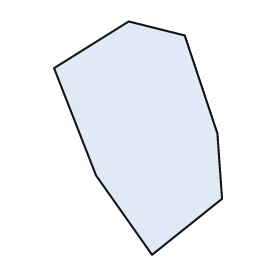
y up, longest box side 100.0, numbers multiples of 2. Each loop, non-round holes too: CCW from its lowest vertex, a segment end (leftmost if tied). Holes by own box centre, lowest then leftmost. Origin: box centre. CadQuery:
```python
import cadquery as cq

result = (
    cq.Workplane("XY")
    .moveTo(6.0, -50.0)
    .lineTo(36.0, -26.0)
    .lineTo(34.0, 2.0)
    .lineTo(20.0, 44.0)
    .lineTo(-4.0, 50.0)
    .lineTo(-36.0, 30.0)
    .lineTo(-18.0, -16.0)
    .close()
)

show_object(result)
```